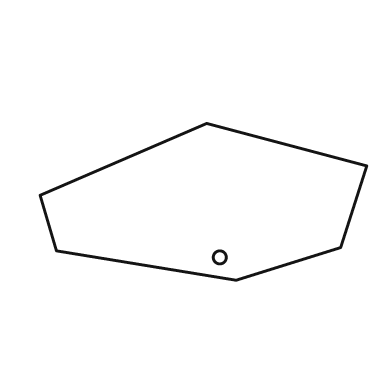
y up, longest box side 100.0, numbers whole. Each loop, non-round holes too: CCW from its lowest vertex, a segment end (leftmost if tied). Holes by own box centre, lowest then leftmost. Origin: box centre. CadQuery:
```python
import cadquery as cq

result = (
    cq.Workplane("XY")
    .moveTo(10.0, -24.0)
    .lineTo(42.0, -14.0)
    .lineTo(50.0, 11.0)
    .lineTo(1.0, 24.0)
    .lineTo(-50.0, 2.0)
    .lineTo(-45.0, -15.0)
    .close()
    .moveTo(5.0, -17.0)
    .circle(2.0)
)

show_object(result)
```